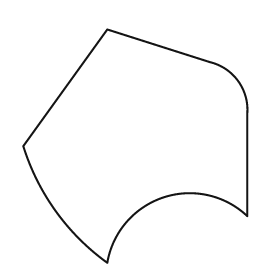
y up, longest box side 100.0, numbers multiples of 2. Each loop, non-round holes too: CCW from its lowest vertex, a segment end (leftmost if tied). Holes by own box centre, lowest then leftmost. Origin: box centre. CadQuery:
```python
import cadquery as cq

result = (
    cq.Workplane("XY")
    .moveTo(-12.0, -50.0)
    .threePointArc((12.0, -22.0), (48.0, -30.0))
    .lineTo(48.0, 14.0)
    .threePointArc((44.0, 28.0), (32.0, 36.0))
    .lineTo(-12.0, 50.0)
    .lineTo(-48.0, 0.0)
    .threePointArc((-34.0, -28.0), (-12.0, -50.0))
    .close()
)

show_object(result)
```